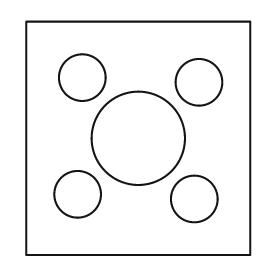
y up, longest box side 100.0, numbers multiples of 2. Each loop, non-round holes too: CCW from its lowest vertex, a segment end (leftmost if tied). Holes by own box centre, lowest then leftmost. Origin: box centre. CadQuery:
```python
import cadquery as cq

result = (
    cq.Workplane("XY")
    .moveTo(-48.0, -50.0)
    .lineTo(48.0, -50.0)
    .lineTo(48.0, 50.0)
    .lineTo(-48.0, 50.0)
    .close()
    .moveTo(24.0, -26.0)
    .circle(10.0)
    .moveTo(-26.0, -24.0)
    .circle(10.0)
    .moveTo(0.0, 0.0)
    .circle(20.0)
    .moveTo(26.0, 24.0)
    .circle(10.0)
    .moveTo(-24.0, 26.0)
    .circle(10.0)
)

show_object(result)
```